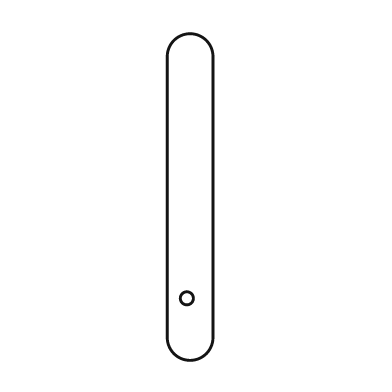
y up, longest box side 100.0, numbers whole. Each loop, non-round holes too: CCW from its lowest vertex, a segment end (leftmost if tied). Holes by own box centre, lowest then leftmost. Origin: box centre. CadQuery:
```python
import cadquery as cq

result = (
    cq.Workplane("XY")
    .moveTo(-7.0, -43.0)
    .threePointArc((0.0, -50.0), (7.0, -43.0))
    .lineTo(7.0, 43.0)
    .threePointArc((0.0, 50.0), (-7.0, 43.0))
    .close()
    .moveTo(-1.0, -31.0)
    .circle(2.0)
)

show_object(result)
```